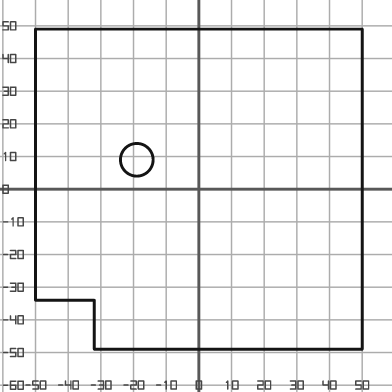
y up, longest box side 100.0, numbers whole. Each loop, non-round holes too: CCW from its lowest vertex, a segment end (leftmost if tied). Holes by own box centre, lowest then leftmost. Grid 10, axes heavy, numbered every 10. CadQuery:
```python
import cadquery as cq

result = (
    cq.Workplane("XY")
    .moveTo(-32.0, -49.0)
    .lineTo(50.0, -49.0)
    .lineTo(50.0, 49.0)
    .lineTo(-50.0, 49.0)
    .lineTo(-50.0, -34.0)
    .lineTo(-32.0, -34.0)
    .close()
    .moveTo(-19.0, 9.0)
    .circle(5.0)
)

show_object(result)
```